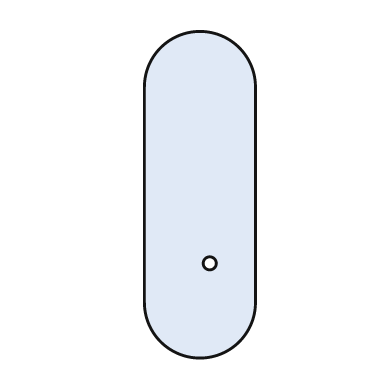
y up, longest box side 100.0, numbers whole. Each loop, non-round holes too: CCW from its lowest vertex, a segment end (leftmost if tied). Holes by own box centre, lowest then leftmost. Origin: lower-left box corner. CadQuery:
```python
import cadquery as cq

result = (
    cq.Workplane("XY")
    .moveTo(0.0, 17.0)
    .threePointArc((17.0, 0.0), (34.0, 17.0))
    .lineTo(34.0, 83.0)
    .threePointArc((17.0, 100.0), (0.0, 83.0))
    .close()
    .moveTo(20.0, 29.0)
    .circle(2.0)
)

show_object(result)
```